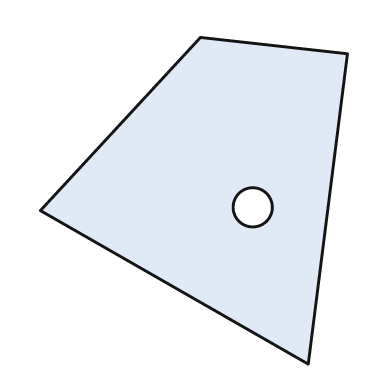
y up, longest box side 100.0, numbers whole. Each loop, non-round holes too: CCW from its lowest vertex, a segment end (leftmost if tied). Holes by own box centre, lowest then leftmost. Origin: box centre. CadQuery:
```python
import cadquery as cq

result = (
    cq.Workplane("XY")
    .moveTo(35.0, -50.0)
    .lineTo(47.0, 45.0)
    .lineTo(2.0, 50.0)
    .lineTo(-47.0, -3.0)
    .close()
    .moveTo(18.0, -2.0)
    .circle(6.0)
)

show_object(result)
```